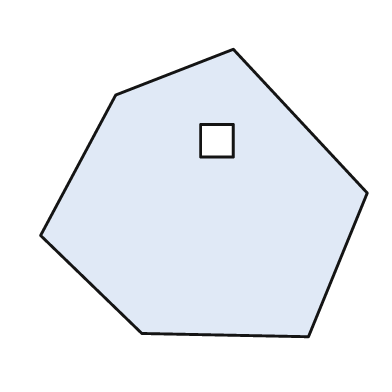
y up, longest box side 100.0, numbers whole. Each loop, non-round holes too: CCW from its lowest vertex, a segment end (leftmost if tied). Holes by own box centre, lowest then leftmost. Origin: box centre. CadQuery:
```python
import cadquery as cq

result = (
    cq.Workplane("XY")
    .moveTo(32.0, -44.0)
    .lineTo(50.0, 0.0)
    .lineTo(9.0, 44.0)
    .lineTo(-27.0, 30.0)
    .lineTo(-50.0, -13.0)
    .lineTo(-19.0, -43.0)
    .close()
    .moveTo(-1.0, 11.0)
    .lineTo(9.0, 11.0)
    .lineTo(9.0, 21.0)
    .lineTo(-1.0, 21.0)
    .close()
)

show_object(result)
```